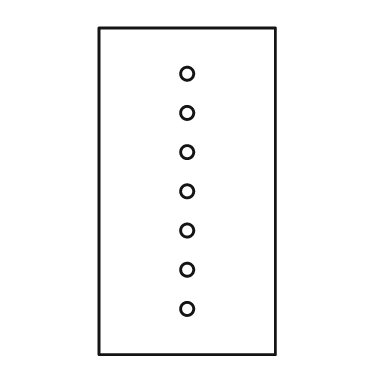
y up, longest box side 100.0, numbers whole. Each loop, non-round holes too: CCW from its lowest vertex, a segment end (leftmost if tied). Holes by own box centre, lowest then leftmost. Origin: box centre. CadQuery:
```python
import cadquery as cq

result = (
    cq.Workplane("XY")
    .moveTo(-27.0, -50.0)
    .lineTo(27.0, -50.0)
    .lineTo(27.0, 50.0)
    .lineTo(-27.0, 50.0)
    .close()
    .moveTo(0.0, -36.0)
    .circle(2.0)
    .moveTo(0.0, -24.0)
    .circle(2.0)
    .moveTo(0.0, -12.0)
    .circle(2.0)
    .moveTo(0.0, 0.0)
    .circle(2.0)
    .moveTo(0.0, 12.0)
    .circle(2.0)
    .moveTo(0.0, 24.0)
    .circle(2.0)
    .moveTo(0.0, 36.0)
    .circle(2.0)
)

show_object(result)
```